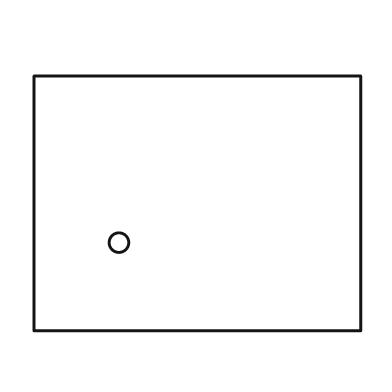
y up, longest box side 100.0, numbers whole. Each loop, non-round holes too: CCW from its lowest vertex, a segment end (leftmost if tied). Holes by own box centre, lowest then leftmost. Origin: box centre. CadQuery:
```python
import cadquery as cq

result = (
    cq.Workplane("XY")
    .moveTo(-50.0, -39.0)
    .lineTo(50.0, -39.0)
    .lineTo(50.0, 39.0)
    .lineTo(-50.0, 39.0)
    .close()
    .moveTo(-24.0, -12.0)
    .circle(3.0)
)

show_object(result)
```